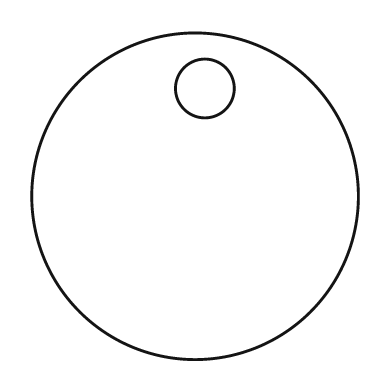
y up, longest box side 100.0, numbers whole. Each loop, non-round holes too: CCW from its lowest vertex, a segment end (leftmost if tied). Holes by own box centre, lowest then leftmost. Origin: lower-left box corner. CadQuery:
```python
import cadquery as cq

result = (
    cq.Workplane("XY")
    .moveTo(50.0, 50.0)
    .circle(50.0)
    .moveTo(53.0, 83.0)
    .circle(9.0)
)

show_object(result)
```